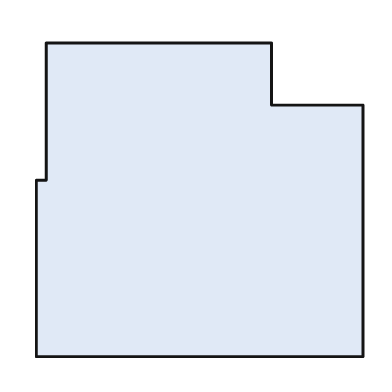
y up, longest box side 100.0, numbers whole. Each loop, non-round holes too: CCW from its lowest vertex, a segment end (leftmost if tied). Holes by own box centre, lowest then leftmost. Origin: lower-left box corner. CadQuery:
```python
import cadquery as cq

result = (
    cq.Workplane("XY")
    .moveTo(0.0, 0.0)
    .lineTo(100.0, 0.0)
    .lineTo(100.0, 77.0)
    .lineTo(72.0, 77.0)
    .lineTo(72.0, 96.0)
    .lineTo(3.0, 96.0)
    .lineTo(3.0, 54.0)
    .lineTo(0.0, 54.0)
    .close()
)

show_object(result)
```